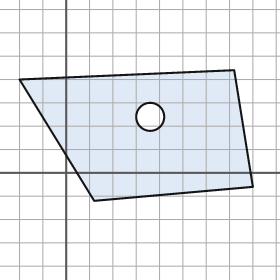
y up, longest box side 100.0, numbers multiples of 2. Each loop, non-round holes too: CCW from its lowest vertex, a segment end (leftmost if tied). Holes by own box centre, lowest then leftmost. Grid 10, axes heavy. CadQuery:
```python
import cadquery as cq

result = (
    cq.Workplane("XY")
    .moveTo(12.0, -12.0)
    .lineTo(80.0, -6.0)
    .lineTo(72.0, 44.0)
    .lineTo(-20.0, 40.0)
    .close()
    .moveTo(36.0, 24.0)
    .circle(6.0)
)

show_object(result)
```